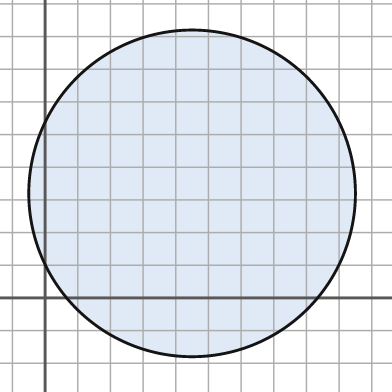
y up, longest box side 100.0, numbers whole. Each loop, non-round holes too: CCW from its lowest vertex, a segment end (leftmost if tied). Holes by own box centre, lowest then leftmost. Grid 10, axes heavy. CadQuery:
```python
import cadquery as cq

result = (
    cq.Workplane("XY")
    .moveTo(45.0, 32.0)
    .circle(50.0)
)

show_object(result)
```